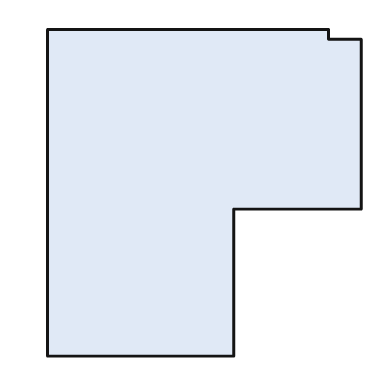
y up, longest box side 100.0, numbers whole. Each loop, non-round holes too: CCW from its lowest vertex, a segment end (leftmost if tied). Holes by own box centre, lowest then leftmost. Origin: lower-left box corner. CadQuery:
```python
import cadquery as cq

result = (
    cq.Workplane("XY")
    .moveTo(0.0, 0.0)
    .lineTo(57.0, 0.0)
    .lineTo(57.0, 45.0)
    .lineTo(96.0, 45.0)
    .lineTo(96.0, 97.0)
    .lineTo(86.0, 97.0)
    .lineTo(86.0, 100.0)
    .lineTo(0.0, 100.0)
    .close()
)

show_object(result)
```